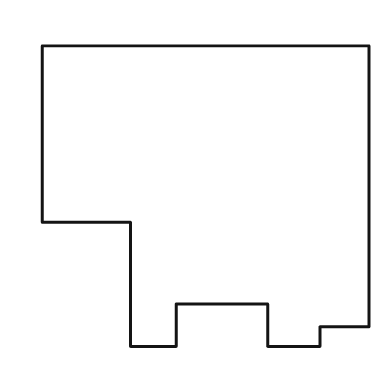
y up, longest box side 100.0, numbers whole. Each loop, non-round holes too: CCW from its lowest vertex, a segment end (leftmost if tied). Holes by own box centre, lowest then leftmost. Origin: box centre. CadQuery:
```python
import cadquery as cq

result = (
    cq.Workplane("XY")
    .moveTo(-23.0, -46.0)
    .lineTo(-9.0, -46.0)
    .lineTo(-9.0, -33.0)
    .lineTo(19.0, -33.0)
    .lineTo(19.0, -46.0)
    .lineTo(35.0, -46.0)
    .lineTo(35.0, -40.0)
    .lineTo(50.0, -40.0)
    .lineTo(50.0, 46.0)
    .lineTo(-50.0, 46.0)
    .lineTo(-50.0, -8.0)
    .lineTo(-23.0, -8.0)
    .close()
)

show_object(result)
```